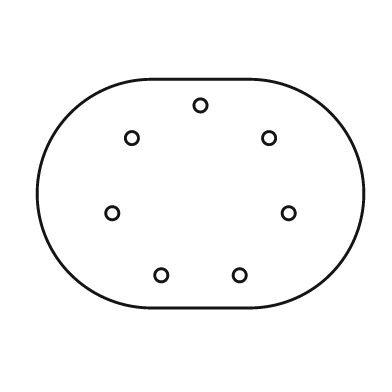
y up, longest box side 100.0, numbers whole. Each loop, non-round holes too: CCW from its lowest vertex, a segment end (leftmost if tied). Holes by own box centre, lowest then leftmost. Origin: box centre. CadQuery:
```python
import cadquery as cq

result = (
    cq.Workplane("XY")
    .moveTo(-15.0, -35.0)
    .lineTo(15.0, -35.0)
    .threePointArc((50.0, 0.0), (15.0, 35.0))
    .lineTo(-15.0, 35.0)
    .threePointArc((-50.0, 0.0), (-15.0, -35.0))
    .close()
    .moveTo(-12.0, -25.0)
    .circle(2.0)
    .moveTo(12.0, -25.0)
    .circle(2.0)
    .moveTo(-27.0, -6.0)
    .circle(2.0)
    .moveTo(27.0, -6.0)
    .circle(2.0)
    .moveTo(-21.0, 17.0)
    .circle(2.0)
    .moveTo(21.0, 17.0)
    .circle(2.0)
    .moveTo(0.0, 27.0)
    .circle(2.0)
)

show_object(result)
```